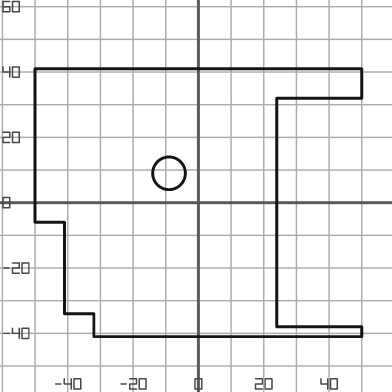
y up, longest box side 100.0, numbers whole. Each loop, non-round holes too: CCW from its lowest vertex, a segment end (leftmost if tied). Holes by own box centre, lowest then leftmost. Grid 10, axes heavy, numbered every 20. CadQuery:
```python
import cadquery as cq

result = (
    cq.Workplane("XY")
    .moveTo(-32.0, -41.0)
    .lineTo(50.0, -41.0)
    .lineTo(50.0, -38.0)
    .lineTo(24.0, -38.0)
    .lineTo(24.0, 32.0)
    .lineTo(50.0, 32.0)
    .lineTo(50.0, 41.0)
    .lineTo(-50.0, 41.0)
    .lineTo(-50.0, -6.0)
    .lineTo(-41.0, -6.0)
    .lineTo(-41.0, -34.0)
    .lineTo(-32.0, -34.0)
    .close()
    .moveTo(-9.0, 9.0)
    .circle(5.0)
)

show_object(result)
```